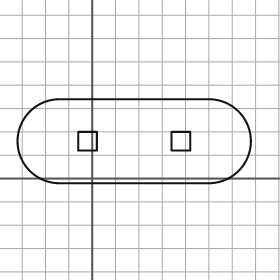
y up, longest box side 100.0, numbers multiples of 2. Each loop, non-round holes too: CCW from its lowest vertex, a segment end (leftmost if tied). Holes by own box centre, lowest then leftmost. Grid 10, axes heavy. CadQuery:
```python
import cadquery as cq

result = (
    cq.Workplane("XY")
    .moveTo(-14.0, -2.0)
    .lineTo(50.0, -2.0)
    .threePointArc((68.0, 16.0), (50.0, 34.0))
    .lineTo(-14.0, 34.0)
    .threePointArc((-32.0, 16.0), (-14.0, -2.0))
    .close()
    .moveTo(-6.0, 12.0)
    .lineTo(2.0, 12.0)
    .lineTo(2.0, 20.0)
    .lineTo(-6.0, 20.0)
    .close()
    .moveTo(34.0, 12.0)
    .lineTo(42.0, 12.0)
    .lineTo(42.0, 20.0)
    .lineTo(34.0, 20.0)
    .close()
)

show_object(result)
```